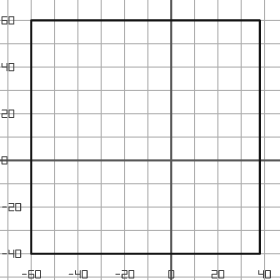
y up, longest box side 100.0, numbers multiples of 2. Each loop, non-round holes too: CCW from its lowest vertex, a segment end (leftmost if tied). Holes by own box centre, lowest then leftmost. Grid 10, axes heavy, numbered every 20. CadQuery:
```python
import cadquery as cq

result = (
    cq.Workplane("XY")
    .moveTo(-60.0, -40.0)
    .lineTo(38.0, -40.0)
    .lineTo(38.0, 60.0)
    .lineTo(-60.0, 60.0)
    .close()
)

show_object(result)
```